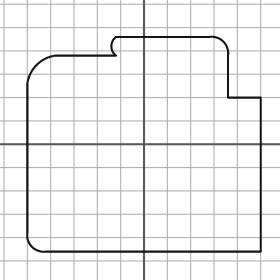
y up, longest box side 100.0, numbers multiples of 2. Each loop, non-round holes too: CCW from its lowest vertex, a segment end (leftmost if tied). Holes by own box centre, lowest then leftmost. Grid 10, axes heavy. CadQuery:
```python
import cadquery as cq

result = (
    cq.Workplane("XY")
    .moveTo(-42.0, -46.0)
    .lineTo(50.0, -46.0)
    .lineTo(50.0, 20.0)
    .lineTo(36.0, 20.0)
    .lineTo(36.0, 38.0)
    .threePointArc((34.0, 44.0), (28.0, 46.0))
    .lineTo(-12.0, 46.0)
    .threePointArc((-14.0, 42.0), (-12.0, 38.0))
    .lineTo(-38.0, 38.0)
    .threePointArc((-46.0, 34.0), (-50.0, 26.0))
    .lineTo(-50.0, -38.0)
    .threePointArc((-48.0, -44.0), (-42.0, -46.0))
    .close()
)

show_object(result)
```